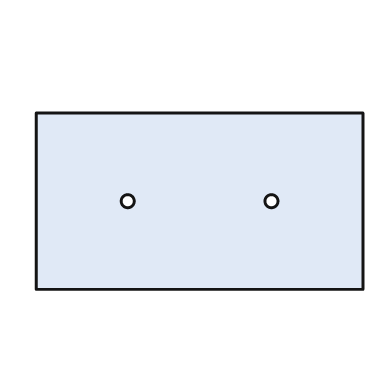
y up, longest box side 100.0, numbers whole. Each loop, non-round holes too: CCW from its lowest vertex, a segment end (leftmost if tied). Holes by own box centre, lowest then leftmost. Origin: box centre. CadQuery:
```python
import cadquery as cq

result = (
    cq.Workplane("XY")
    .moveTo(-50.0, -27.0)
    .lineTo(50.0, -27.0)
    .lineTo(50.0, 27.0)
    .lineTo(-50.0, 27.0)
    .close()
    .moveTo(-22.0, 0.0)
    .circle(2.0)
    .moveTo(22.0, 0.0)
    .circle(2.0)
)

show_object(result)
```